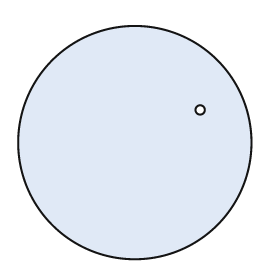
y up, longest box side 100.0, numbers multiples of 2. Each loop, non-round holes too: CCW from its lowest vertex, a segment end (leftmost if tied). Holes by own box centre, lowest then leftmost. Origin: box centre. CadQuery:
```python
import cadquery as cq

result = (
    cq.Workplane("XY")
    .moveTo(0.0, 0.0)
    .circle(50.0)
    .moveTo(28.0, 14.0)
    .circle(2.0)
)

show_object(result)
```